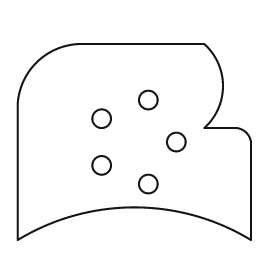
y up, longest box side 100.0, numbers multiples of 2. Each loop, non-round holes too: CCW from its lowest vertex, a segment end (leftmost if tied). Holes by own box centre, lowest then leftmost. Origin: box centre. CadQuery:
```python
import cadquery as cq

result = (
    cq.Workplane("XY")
    .moveTo(-50.0, -42.0)
    .threePointArc((0.0, -28.0), (50.0, -42.0))
    .lineTo(50.0, 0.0)
    .threePointArc((48.0, 4.0), (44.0, 6.0))
    .lineTo(30.0, 6.0)
    .threePointArc((38.0, 24.0), (30.0, 42.0))
    .lineTo(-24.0, 42.0)
    .threePointArc((-42.0, 34.0), (-50.0, 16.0))
    .close()
    .moveTo(6.0, -18.0)
    .circle(4.0)
    .moveTo(-14.0, -10.0)
    .circle(4.0)
    .moveTo(18.0, 0.0)
    .circle(4.0)
    .moveTo(-14.0, 10.0)
    .circle(4.0)
    .moveTo(6.0, 18.0)
    .circle(4.0)
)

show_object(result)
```